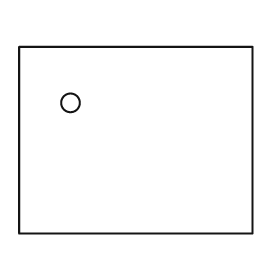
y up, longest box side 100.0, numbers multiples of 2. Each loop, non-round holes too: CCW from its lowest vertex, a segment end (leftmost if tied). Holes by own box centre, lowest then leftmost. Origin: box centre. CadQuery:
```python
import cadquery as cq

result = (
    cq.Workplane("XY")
    .moveTo(-50.0, -40.0)
    .lineTo(50.0, -40.0)
    .lineTo(50.0, 40.0)
    .lineTo(-50.0, 40.0)
    .close()
    .moveTo(-28.0, 16.0)
    .circle(4.0)
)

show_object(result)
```